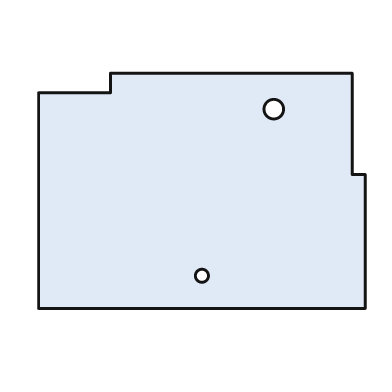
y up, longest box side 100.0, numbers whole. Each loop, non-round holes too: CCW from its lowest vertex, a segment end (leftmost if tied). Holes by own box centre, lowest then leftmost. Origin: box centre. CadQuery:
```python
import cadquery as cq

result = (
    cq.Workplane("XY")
    .moveTo(-50.0, -36.0)
    .lineTo(50.0, -36.0)
    .lineTo(50.0, 5.0)
    .lineTo(46.0, 5.0)
    .lineTo(46.0, 36.0)
    .lineTo(-28.0, 36.0)
    .lineTo(-28.0, 30.0)
    .lineTo(-50.0, 30.0)
    .close()
    .moveTo(0.0, -26.0)
    .circle(2.0)
    .moveTo(22.0, 25.0)
    .circle(3.0)
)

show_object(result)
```